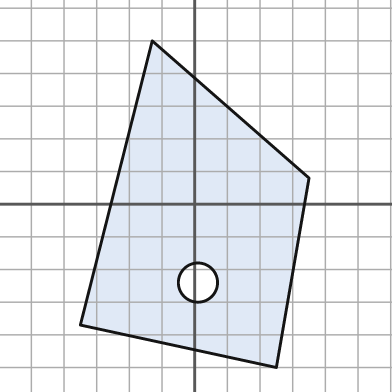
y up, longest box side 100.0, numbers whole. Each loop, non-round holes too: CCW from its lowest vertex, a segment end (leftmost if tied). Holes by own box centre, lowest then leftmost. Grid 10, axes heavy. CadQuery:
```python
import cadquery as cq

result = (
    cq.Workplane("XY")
    .moveTo(25.0, -50.0)
    .lineTo(35.0, 8.0)
    .lineTo(-13.0, 50.0)
    .lineTo(-35.0, -37.0)
    .close()
    .moveTo(1.0, -24.0)
    .circle(6.0)
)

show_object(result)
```